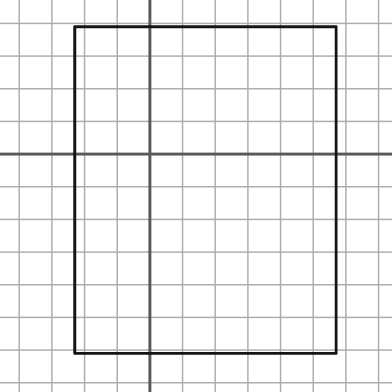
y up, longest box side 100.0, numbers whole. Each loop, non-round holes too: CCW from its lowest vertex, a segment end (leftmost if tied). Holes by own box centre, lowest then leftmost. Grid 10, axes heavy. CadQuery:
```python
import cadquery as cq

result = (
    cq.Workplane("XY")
    .moveTo(-23.0, -61.0)
    .lineTo(57.0, -61.0)
    .lineTo(57.0, 39.0)
    .lineTo(-23.0, 39.0)
    .close()
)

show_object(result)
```